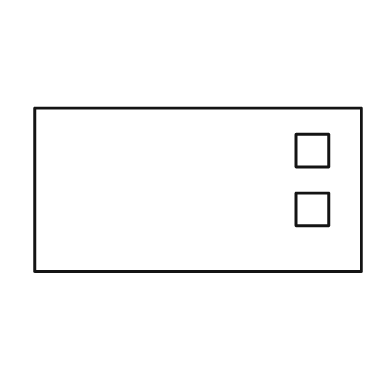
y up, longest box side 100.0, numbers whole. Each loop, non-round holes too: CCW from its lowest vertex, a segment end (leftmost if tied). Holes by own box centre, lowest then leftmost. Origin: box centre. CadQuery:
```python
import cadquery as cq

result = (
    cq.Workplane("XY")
    .moveTo(-50.0, -25.0)
    .lineTo(50.0, -25.0)
    .lineTo(50.0, 25.0)
    .lineTo(-50.0, 25.0)
    .close()
    .moveTo(30.0, -11.0)
    .lineTo(40.0, -11.0)
    .lineTo(40.0, -1.0)
    .lineTo(30.0, -1.0)
    .close()
    .moveTo(30.0, 7.0)
    .lineTo(40.0, 7.0)
    .lineTo(40.0, 17.0)
    .lineTo(30.0, 17.0)
    .close()
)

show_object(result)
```